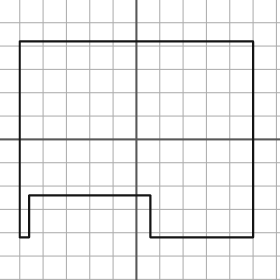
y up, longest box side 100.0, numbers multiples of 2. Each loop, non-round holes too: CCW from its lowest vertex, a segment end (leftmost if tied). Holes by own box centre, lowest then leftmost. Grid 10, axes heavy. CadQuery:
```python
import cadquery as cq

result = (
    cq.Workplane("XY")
    .moveTo(-50.0, -42.0)
    .lineTo(-46.0, -42.0)
    .lineTo(-46.0, -24.0)
    .lineTo(6.0, -24.0)
    .lineTo(6.0, -42.0)
    .lineTo(50.0, -42.0)
    .lineTo(50.0, 42.0)
    .lineTo(-50.0, 42.0)
    .close()
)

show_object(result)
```